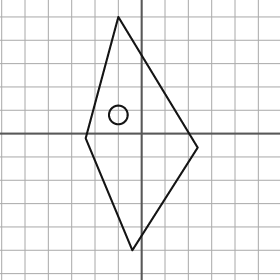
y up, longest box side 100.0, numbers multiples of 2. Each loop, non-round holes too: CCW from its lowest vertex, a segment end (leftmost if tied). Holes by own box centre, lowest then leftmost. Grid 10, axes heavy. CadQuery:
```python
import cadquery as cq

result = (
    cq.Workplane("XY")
    .moveTo(-4.0, -50.0)
    .lineTo(24.0, -6.0)
    .lineTo(-10.0, 50.0)
    .lineTo(-24.0, -2.0)
    .close()
    .moveTo(-10.0, 8.0)
    .circle(4.0)
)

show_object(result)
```